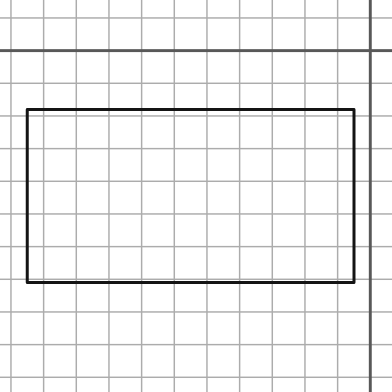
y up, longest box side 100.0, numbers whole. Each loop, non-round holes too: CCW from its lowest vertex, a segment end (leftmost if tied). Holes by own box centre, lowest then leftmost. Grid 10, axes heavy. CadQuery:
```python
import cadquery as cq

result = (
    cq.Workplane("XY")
    .moveTo(-105.0, -71.0)
    .lineTo(-5.0, -71.0)
    .lineTo(-5.0, -18.0)
    .lineTo(-105.0, -18.0)
    .close()
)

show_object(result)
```